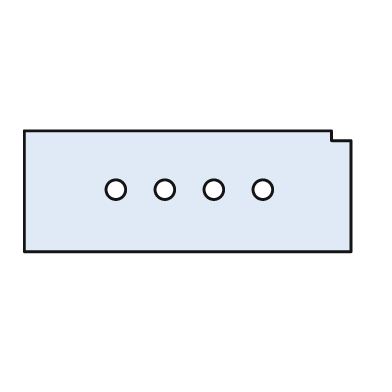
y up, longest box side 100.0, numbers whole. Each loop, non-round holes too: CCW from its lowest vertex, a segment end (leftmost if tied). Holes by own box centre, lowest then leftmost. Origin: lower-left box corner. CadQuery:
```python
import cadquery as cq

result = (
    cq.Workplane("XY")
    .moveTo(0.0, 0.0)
    .lineTo(100.0, 0.0)
    .lineTo(100.0, 34.0)
    .lineTo(94.0, 34.0)
    .lineTo(94.0, 37.0)
    .lineTo(0.0, 37.0)
    .close()
    .moveTo(28.0, 19.0)
    .circle(3.0)
    .moveTo(43.0, 19.0)
    .circle(3.0)
    .moveTo(58.0, 19.0)
    .circle(3.0)
    .moveTo(73.0, 19.0)
    .circle(3.0)
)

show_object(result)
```